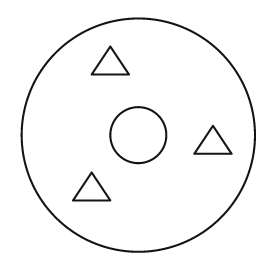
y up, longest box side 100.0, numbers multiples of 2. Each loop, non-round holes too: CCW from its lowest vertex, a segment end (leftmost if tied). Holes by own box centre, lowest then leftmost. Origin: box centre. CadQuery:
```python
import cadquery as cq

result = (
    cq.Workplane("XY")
    .moveTo(0.0, 0.0)
    .circle(50.0)
    .moveTo(-28.0, -28.0)
    .lineTo(-12.0, -28.0)
    .lineTo(-20.0, -16.0)
    .close()
    .moveTo(24.0, -8.0)
    .lineTo(40.0, -8.0)
    .lineTo(32.0, 4.0)
    .close()
    .moveTo(0.0, 0.0)
    .circle(12.0)
    .moveTo(-20.0, 26.0)
    .lineTo(-4.0, 26.0)
    .lineTo(-12.0, 38.0)
    .close()
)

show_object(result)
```